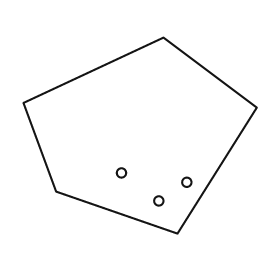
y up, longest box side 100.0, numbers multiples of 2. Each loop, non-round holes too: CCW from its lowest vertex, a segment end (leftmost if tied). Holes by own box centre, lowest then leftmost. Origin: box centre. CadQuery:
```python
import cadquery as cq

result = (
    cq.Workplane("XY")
    .moveTo(16.0, -42.0)
    .lineTo(50.0, 12.0)
    .lineTo(10.0, 42.0)
    .lineTo(-50.0, 14.0)
    .lineTo(-36.0, -24.0)
    .close()
    .moveTo(8.0, -28.0)
    .circle(2.0)
    .moveTo(20.0, -20.0)
    .circle(2.0)
    .moveTo(-8.0, -16.0)
    .circle(2.0)
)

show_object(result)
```